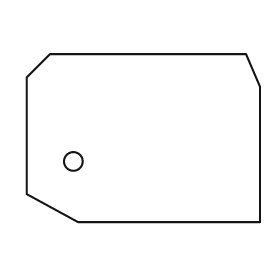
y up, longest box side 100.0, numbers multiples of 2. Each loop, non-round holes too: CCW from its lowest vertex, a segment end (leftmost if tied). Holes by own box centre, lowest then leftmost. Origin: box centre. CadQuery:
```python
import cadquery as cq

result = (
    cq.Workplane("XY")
    .moveTo(-28.0, -36.0)
    .lineTo(50.0, -36.0)
    .lineTo(50.0, 22.0)
    .lineTo(44.0, 36.0)
    .lineTo(-40.0, 36.0)
    .lineTo(-50.0, 26.0)
    .lineTo(-50.0, -24.0)
    .close()
    .moveTo(-30.0, -10.0)
    .circle(4.0)
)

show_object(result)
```